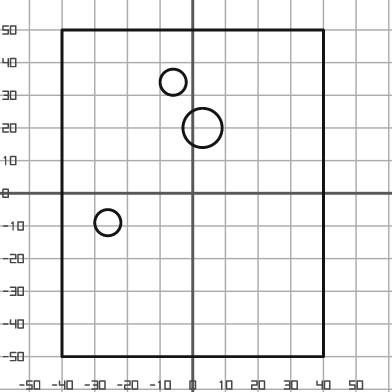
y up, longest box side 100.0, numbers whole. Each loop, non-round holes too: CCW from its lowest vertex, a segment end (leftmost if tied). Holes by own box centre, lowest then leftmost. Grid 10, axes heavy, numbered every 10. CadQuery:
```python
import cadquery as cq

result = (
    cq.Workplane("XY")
    .moveTo(-40.0, -50.0)
    .lineTo(40.0, -50.0)
    .lineTo(40.0, 50.0)
    .lineTo(-40.0, 50.0)
    .close()
    .moveTo(-26.0, -9.0)
    .circle(4.0)
    .moveTo(3.0, 20.0)
    .circle(6.0)
    .moveTo(-6.0, 34.0)
    .circle(4.0)
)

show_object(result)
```